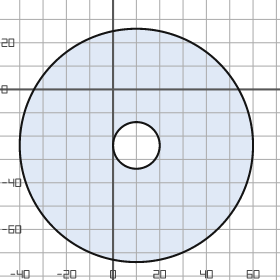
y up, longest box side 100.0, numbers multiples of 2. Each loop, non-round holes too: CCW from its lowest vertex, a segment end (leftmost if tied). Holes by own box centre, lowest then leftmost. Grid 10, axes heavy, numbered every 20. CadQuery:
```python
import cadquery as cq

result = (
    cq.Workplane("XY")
    .moveTo(10.0, -24.0)
    .circle(50.0)
    .moveTo(10.0, -24.0)
    .circle(10.0)
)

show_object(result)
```